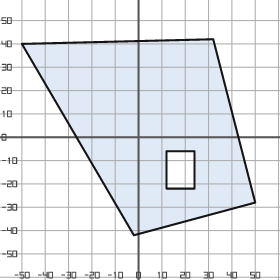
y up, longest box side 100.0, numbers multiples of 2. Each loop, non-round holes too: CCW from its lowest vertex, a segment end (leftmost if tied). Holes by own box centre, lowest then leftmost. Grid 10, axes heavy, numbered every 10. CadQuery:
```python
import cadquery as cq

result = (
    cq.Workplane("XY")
    .moveTo(-2.0, -42.0)
    .lineTo(50.0, -28.0)
    .lineTo(32.0, 42.0)
    .lineTo(-50.0, 40.0)
    .close()
    .moveTo(12.0, -22.0)
    .lineTo(24.0, -22.0)
    .lineTo(24.0, -6.0)
    .lineTo(12.0, -6.0)
    .close()
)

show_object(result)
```